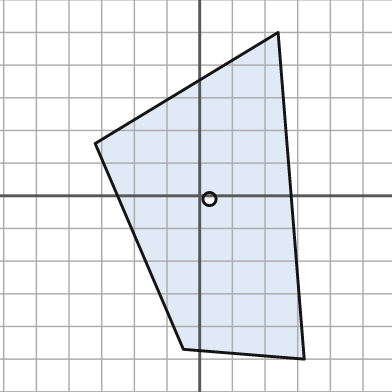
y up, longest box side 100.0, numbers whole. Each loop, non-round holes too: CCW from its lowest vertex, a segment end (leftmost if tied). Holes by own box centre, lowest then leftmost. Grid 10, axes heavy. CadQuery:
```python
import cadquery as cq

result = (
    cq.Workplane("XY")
    .moveTo(32.0, -50.0)
    .lineTo(24.0, 50.0)
    .lineTo(-32.0, 16.0)
    .lineTo(-5.0, -47.0)
    .close()
    .moveTo(3.0, -1.0)
    .circle(2.0)
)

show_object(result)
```